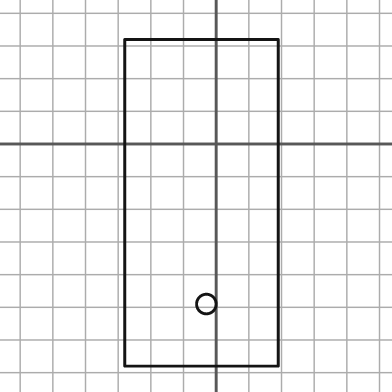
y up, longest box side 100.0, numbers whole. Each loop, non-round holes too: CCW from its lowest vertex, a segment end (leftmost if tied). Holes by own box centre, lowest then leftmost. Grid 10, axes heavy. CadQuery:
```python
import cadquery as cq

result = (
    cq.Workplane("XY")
    .moveTo(-28.0, -68.0)
    .lineTo(19.0, -68.0)
    .lineTo(19.0, 32.0)
    .lineTo(-28.0, 32.0)
    .close()
    .moveTo(-3.0, -49.0)
    .circle(3.0)
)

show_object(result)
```